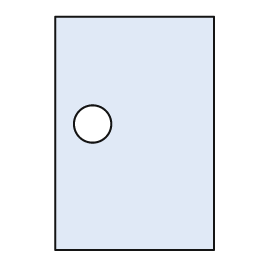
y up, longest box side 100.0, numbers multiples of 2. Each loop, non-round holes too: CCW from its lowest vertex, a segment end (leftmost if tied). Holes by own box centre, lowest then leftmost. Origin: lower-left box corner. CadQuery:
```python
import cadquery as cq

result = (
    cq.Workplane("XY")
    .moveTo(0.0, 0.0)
    .lineTo(68.0, 0.0)
    .lineTo(68.0, 100.0)
    .lineTo(0.0, 100.0)
    .close()
    .moveTo(16.0, 54.0)
    .circle(8.0)
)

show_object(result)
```